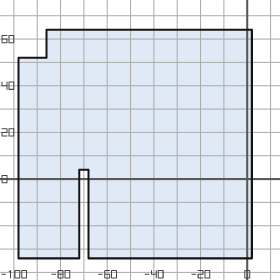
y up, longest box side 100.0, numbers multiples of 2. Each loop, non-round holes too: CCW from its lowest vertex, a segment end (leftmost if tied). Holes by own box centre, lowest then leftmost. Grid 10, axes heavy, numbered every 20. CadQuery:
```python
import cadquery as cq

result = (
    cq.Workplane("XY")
    .moveTo(-98.0, -34.0)
    .lineTo(-72.0, -34.0)
    .lineTo(-72.0, 4.0)
    .lineTo(-68.0, 4.0)
    .lineTo(-68.0, -34.0)
    .lineTo(2.0, -34.0)
    .lineTo(2.0, 64.0)
    .lineTo(-86.0, 64.0)
    .lineTo(-86.0, 52.0)
    .lineTo(-98.0, 52.0)
    .close()
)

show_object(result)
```